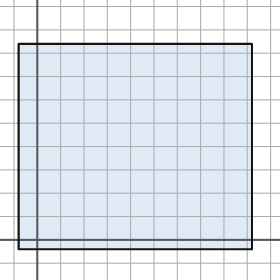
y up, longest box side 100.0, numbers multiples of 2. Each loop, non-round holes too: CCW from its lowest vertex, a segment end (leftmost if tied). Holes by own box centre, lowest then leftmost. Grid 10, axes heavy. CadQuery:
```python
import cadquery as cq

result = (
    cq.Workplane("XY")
    .moveTo(-8.0, -4.0)
    .lineTo(92.0, -4.0)
    .lineTo(92.0, 84.0)
    .lineTo(-8.0, 84.0)
    .close()
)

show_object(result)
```